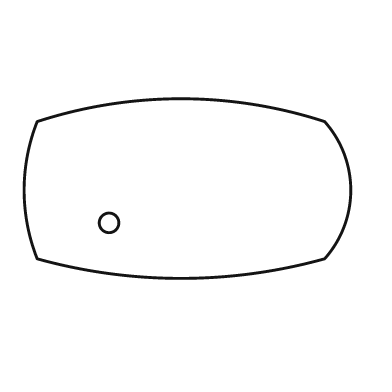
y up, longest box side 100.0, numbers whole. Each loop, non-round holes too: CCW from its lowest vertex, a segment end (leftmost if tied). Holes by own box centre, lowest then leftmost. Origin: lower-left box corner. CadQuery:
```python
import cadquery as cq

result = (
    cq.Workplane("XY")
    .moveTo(4.0, 6.0)
    .threePointArc((48.0, 0.0), (92.0, 6.0))
    .threePointArc((100.0, 27.0), (92.0, 48.0))
    .threePointArc((48.0, 55.0), (4.0, 48.0))
    .threePointArc((0.0, 27.0), (4.0, 6.0))
    .close()
    .moveTo(26.0, 17.0)
    .circle(3.0)
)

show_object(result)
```